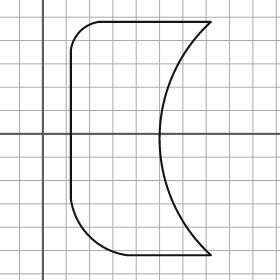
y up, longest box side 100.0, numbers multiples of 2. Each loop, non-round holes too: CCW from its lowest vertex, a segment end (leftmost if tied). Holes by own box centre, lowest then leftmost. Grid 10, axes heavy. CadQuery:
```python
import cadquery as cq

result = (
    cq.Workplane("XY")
    .moveTo(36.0, -52.0)
    .lineTo(72.0, -52.0)
    .threePointArc((50.0, -2.0), (72.0, 48.0))
    .lineTo(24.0, 48.0)
    .threePointArc((16.0, 44.0), (12.0, 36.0))
    .lineTo(12.0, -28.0)
    .threePointArc((20.0, -44.0), (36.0, -52.0))
    .close()
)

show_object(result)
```